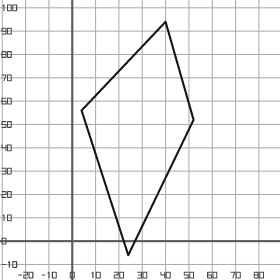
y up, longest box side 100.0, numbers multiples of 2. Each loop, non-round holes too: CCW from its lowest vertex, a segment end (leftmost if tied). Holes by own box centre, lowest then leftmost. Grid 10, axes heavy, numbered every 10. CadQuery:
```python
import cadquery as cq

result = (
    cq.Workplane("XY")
    .moveTo(24.0, -6.0)
    .lineTo(52.0, 52.0)
    .lineTo(40.0, 94.0)
    .lineTo(4.0, 56.0)
    .close()
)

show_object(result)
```